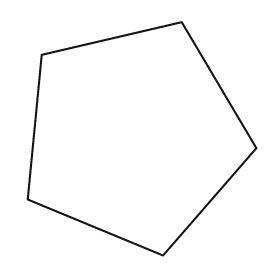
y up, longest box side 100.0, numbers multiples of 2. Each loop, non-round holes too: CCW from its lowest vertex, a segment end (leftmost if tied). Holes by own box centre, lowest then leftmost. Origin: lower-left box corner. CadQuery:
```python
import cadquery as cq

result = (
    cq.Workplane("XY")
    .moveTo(58.0, 0.0)
    .lineTo(98.0, 46.0)
    .lineTo(66.0, 100.0)
    .lineTo(6.0, 86.0)
    .lineTo(0.0, 24.0)
    .close()
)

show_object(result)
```